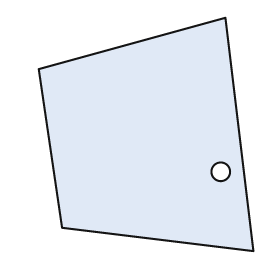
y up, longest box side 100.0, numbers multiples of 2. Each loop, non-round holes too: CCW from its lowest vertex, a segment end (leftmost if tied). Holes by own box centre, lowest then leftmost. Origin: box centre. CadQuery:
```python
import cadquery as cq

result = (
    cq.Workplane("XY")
    .moveTo(46.0, -50.0)
    .lineTo(34.0, 50.0)
    .lineTo(-46.0, 28.0)
    .lineTo(-36.0, -40.0)
    .close()
    .moveTo(32.0, -16.0)
    .circle(4.0)
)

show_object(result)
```